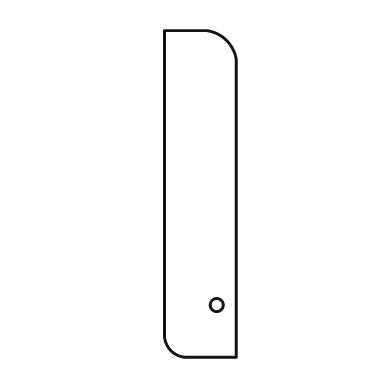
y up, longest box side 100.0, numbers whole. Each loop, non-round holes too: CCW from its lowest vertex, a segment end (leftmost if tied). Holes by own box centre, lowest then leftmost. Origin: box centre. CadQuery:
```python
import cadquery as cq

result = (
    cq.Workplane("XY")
    .moveTo(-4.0, -50.0)
    .lineTo(11.0, -50.0)
    .lineTo(11.0, 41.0)
    .threePointArc((8.0, 47.0), (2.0, 50.0))
    .lineTo(-11.0, 50.0)
    .lineTo(-11.0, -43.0)
    .threePointArc((-9.0, -48.0), (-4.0, -50.0))
    .close()
    .moveTo(5.0, -34.0)
    .circle(2.0)
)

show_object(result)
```